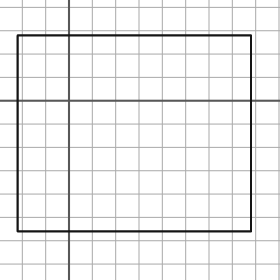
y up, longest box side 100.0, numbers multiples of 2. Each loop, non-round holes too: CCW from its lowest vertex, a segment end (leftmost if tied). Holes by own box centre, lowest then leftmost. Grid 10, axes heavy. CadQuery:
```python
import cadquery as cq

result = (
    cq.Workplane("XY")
    .moveTo(-22.0, -56.0)
    .lineTo(78.0, -56.0)
    .lineTo(78.0, 28.0)
    .lineTo(-22.0, 28.0)
    .close()
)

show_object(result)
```